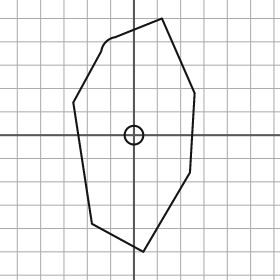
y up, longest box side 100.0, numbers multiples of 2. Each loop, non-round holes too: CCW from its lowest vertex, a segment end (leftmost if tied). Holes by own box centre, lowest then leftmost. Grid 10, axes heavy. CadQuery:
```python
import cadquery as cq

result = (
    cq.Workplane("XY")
    .moveTo(4.0, -50.0)
    .lineTo(24.0, -16.0)
    .lineTo(26.0, 18.0)
    .lineTo(12.0, 50.0)
    .lineTo(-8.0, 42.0)
    .threePointArc((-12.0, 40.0), (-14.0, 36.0))
    .lineTo(-26.0, 14.0)
    .lineTo(-18.0, -38.0)
    .close()
    .moveTo(0.0, 0.0)
    .circle(4.0)
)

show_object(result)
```